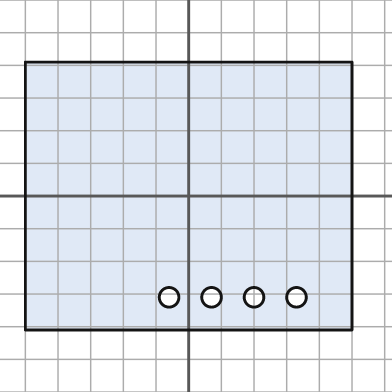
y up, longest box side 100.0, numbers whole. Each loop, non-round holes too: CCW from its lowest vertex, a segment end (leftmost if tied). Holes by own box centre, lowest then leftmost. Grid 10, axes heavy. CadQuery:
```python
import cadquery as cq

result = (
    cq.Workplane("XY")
    .moveTo(-50.0, -41.0)
    .lineTo(50.0, -41.0)
    .lineTo(50.0, 41.0)
    .lineTo(-50.0, 41.0)
    .close()
    .moveTo(-6.0, -31.0)
    .circle(3.0)
    .moveTo(7.0, -31.0)
    .circle(3.0)
    .moveTo(20.0, -31.0)
    .circle(3.0)
    .moveTo(33.0, -31.0)
    .circle(3.0)
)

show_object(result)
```